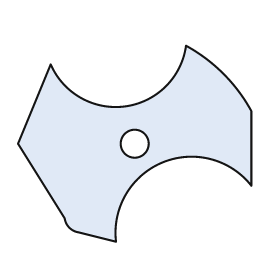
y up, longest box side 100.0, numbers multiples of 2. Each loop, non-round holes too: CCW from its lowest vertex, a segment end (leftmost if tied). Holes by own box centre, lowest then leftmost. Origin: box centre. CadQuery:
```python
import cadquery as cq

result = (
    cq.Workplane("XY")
    .moveTo(-8.0, -42.0)
    .threePointArc((12.0, -8.0), (50.0, -18.0))
    .lineTo(50.0, 14.0)
    .threePointArc((38.0, 30.0), (22.0, 42.0))
    .threePointArc((-4.0, 16.0), (-36.0, 34.0))
    .lineTo(-50.0, 0.0)
    .lineTo(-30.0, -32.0)
    .threePointArc((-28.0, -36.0), (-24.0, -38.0))
    .close()
    .moveTo(0.0, 0.0)
    .circle(6.0)
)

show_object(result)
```